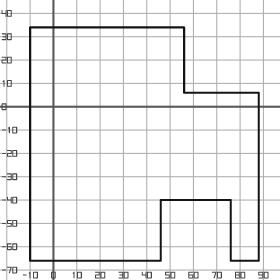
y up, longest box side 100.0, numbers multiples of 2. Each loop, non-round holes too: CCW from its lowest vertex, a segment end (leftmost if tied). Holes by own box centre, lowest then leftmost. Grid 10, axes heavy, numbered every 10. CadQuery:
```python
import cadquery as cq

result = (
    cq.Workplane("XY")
    .moveTo(-10.0, -66.0)
    .lineTo(46.0, -66.0)
    .lineTo(46.0, -40.0)
    .lineTo(76.0, -40.0)
    .lineTo(76.0, -66.0)
    .lineTo(88.0, -66.0)
    .lineTo(88.0, 6.0)
    .lineTo(56.0, 6.0)
    .lineTo(56.0, 34.0)
    .lineTo(-10.0, 34.0)
    .close()
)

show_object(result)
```